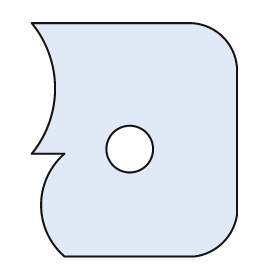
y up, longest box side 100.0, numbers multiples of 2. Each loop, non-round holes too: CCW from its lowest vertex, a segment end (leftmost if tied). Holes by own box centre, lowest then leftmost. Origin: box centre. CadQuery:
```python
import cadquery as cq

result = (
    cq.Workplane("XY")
    .moveTo(-30.0, -50.0)
    .lineTo(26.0, -50.0)
    .threePointArc((38.0, -44.0), (44.0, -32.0))
    .lineTo(44.0, 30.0)
    .threePointArc((38.0, 44.0), (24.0, 50.0))
    .lineTo(-44.0, 50.0)
    .threePointArc((-34.0, 22.0), (-44.0, -6.0))
    .lineTo(-30.0, -6.0)
    .threePointArc((-40.0, -28.0), (-30.0, -50.0))
    .close()
    .moveTo(-2.0, -4.0)
    .circle(10.0)
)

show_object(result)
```